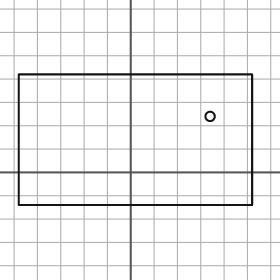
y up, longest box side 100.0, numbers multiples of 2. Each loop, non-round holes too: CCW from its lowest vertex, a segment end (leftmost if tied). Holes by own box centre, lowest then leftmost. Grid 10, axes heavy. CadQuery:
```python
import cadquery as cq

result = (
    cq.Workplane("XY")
    .moveTo(-48.0, -14.0)
    .lineTo(52.0, -14.0)
    .lineTo(52.0, 42.0)
    .lineTo(-48.0, 42.0)
    .close()
    .moveTo(34.0, 24.0)
    .circle(2.0)
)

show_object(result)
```